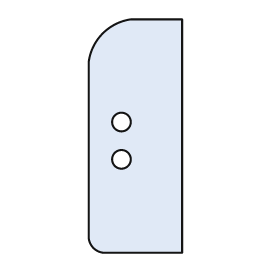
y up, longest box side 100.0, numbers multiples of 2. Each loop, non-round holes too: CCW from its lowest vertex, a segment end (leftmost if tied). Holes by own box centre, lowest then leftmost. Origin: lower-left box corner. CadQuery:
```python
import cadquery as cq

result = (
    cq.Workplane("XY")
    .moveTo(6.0, 0.0)
    .lineTo(40.0, 0.0)
    .lineTo(40.0, 100.0)
    .lineTo(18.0, 100.0)
    .threePointArc((6.0, 94.0), (0.0, 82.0))
    .lineTo(0.0, 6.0)
    .threePointArc((2.0, 2.0), (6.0, 0.0))
    .close()
    .moveTo(14.0, 40.0)
    .circle(4.0)
    .moveTo(14.0, 56.0)
    .circle(4.0)
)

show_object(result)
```